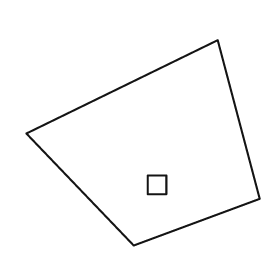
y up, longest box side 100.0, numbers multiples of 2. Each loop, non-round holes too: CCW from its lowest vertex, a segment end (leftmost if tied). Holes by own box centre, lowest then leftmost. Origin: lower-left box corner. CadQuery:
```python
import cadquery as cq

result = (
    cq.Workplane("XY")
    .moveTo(46.0, 0.0)
    .lineTo(100.0, 20.0)
    .lineTo(82.0, 88.0)
    .lineTo(0.0, 48.0)
    .close()
    .moveTo(52.0, 22.0)
    .lineTo(60.0, 22.0)
    .lineTo(60.0, 30.0)
    .lineTo(52.0, 30.0)
    .close()
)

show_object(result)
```